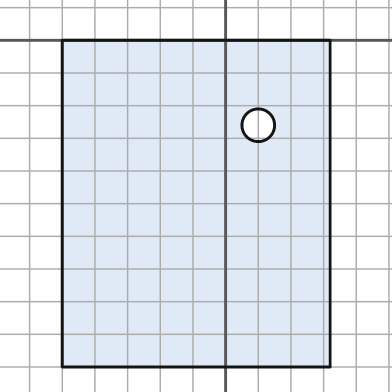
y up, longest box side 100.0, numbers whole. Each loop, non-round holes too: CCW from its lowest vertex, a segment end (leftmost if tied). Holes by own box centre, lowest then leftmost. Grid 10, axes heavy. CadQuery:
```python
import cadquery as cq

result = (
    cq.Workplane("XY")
    .moveTo(-50.0, -100.0)
    .lineTo(32.0, -100.0)
    .lineTo(32.0, 0.0)
    .lineTo(-50.0, 0.0)
    .close()
    .moveTo(10.0, -26.0)
    .circle(5.0)
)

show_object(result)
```